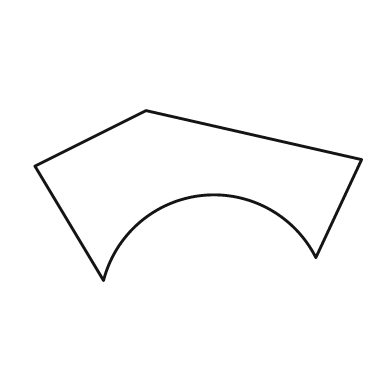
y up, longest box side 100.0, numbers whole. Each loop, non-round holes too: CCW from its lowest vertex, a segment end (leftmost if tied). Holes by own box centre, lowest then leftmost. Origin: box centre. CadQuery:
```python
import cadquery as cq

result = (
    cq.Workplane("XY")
    .moveTo(-29.0, -26.0)
    .threePointArc((1.0, 0.0), (36.0, -19.0))
    .lineTo(50.0, 11.0)
    .lineTo(-16.0, 26.0)
    .lineTo(-50.0, 9.0)
    .close()
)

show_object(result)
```